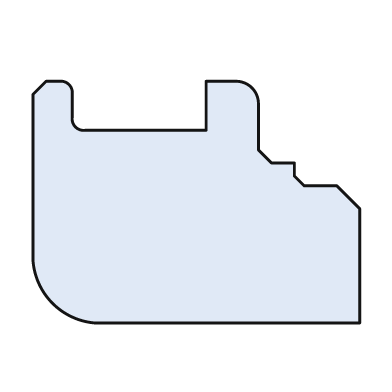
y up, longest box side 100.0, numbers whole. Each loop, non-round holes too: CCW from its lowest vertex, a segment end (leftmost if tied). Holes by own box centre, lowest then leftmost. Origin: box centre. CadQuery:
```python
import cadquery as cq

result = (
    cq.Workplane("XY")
    .moveTo(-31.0, -37.0)
    .lineTo(50.0, -37.0)
    .lineTo(50.0, -2.0)
    .lineTo(43.0, 5.0)
    .lineTo(33.0, 5.0)
    .lineTo(30.0, 8.0)
    .lineTo(30.0, 12.0)
    .lineTo(23.0, 12.0)
    .lineTo(19.0, 16.0)
    .lineTo(19.0, 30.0)
    .threePointArc((17.0, 35.0), (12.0, 37.0))
    .lineTo(3.0, 37.0)
    .lineTo(3.0, 22.0)
    .lineTo(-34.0, 22.0)
    .threePointArc((-37.0, 23.0), (-38.0, 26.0))
    .lineTo(-38.0, 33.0)
    .threePointArc((-39.0, 36.0), (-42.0, 37.0))
    .lineTo(-46.0, 37.0)
    .lineTo(-50.0, 33.0)
    .lineTo(-50.0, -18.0)
    .threePointArc((-44.0, -31.0), (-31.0, -37.0))
    .close()
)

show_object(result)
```